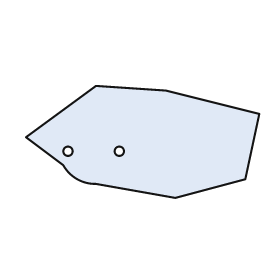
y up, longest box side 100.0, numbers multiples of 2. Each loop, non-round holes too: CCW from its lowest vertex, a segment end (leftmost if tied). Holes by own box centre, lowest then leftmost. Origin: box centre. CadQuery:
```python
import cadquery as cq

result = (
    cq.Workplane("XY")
    .moveTo(14.0, -24.0)
    .lineTo(44.0, -16.0)
    .lineTo(50.0, 12.0)
    .lineTo(10.0, 22.0)
    .lineTo(-20.0, 24.0)
    .lineTo(-50.0, 2.0)
    .lineTo(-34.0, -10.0)
    .threePointArc((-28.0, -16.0), (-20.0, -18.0))
    .close()
    .moveTo(-32.0, -4.0)
    .circle(2.0)
    .moveTo(-10.0, -4.0)
    .circle(2.0)
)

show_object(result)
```